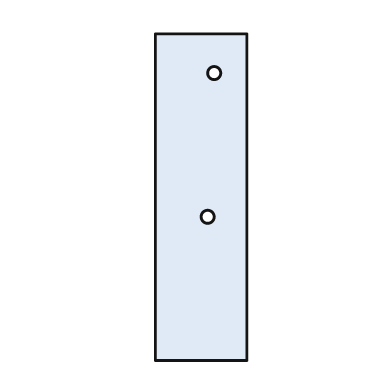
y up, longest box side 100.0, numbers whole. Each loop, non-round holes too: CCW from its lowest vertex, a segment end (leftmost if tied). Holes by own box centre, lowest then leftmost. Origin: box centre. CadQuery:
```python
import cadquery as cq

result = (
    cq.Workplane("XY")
    .moveTo(-14.0, -50.0)
    .lineTo(14.0, -50.0)
    .lineTo(14.0, 50.0)
    .lineTo(-14.0, 50.0)
    .close()
    .moveTo(2.0, -6.0)
    .circle(2.0)
    .moveTo(4.0, 38.0)
    .circle(2.0)
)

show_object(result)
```